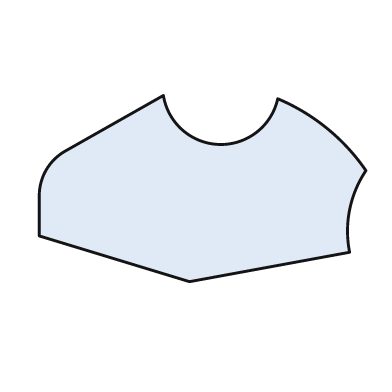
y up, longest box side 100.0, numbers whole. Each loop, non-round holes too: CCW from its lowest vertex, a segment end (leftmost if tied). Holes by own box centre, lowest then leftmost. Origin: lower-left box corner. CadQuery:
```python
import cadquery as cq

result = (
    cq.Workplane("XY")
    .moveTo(46.0, 0.0)
    .lineTo(95.0, 9.0)
    .threePointArc((95.0, 22.0), (100.0, 34.0))
    .threePointArc((88.0, 47.0), (73.0, 56.0))
    .threePointArc((55.0, 42.0), (38.0, 57.0))
    .lineTo(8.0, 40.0)
    .threePointArc((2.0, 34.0), (0.0, 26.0))
    .lineTo(0.0, 14.0)
    .close()
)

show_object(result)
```